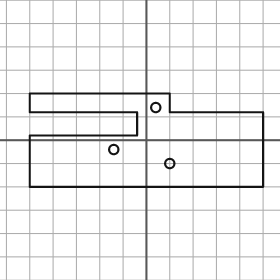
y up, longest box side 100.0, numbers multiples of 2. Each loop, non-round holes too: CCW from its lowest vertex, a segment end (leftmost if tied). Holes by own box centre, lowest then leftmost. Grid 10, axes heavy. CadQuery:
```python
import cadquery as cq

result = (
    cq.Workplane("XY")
    .moveTo(-50.0, -20.0)
    .lineTo(50.0, -20.0)
    .lineTo(50.0, 12.0)
    .lineTo(10.0, 12.0)
    .lineTo(10.0, 20.0)
    .lineTo(-50.0, 20.0)
    .lineTo(-50.0, 12.0)
    .lineTo(-4.0, 12.0)
    .lineTo(-4.0, 2.0)
    .lineTo(-50.0, 2.0)
    .close()
    .moveTo(10.0, -10.0)
    .circle(2.0)
    .moveTo(-14.0, -4.0)
    .circle(2.0)
    .moveTo(4.0, 14.0)
    .circle(2.0)
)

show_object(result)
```